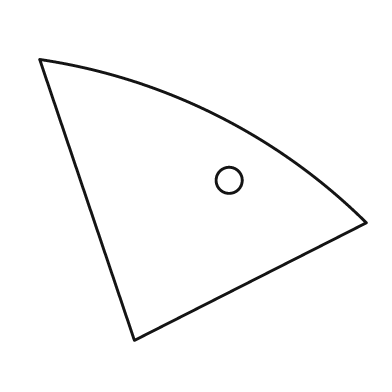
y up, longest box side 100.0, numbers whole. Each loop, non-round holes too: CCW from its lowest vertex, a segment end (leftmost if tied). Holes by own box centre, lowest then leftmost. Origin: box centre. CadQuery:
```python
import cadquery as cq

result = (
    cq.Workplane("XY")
    .moveTo(-21.0, -43.0)
    .lineTo(50.0, -7.0)
    .threePointArc((4.0, 26.0), (-50.0, 43.0))
    .close()
    .moveTo(8.0, 6.0)
    .circle(4.0)
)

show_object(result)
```